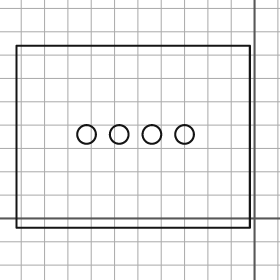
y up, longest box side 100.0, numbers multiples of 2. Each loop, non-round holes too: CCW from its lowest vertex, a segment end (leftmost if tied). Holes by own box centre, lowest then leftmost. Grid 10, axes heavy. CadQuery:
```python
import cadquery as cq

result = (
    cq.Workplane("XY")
    .moveTo(-102.0, -4.0)
    .lineTo(-2.0, -4.0)
    .lineTo(-2.0, 74.0)
    .lineTo(-102.0, 74.0)
    .close()
    .moveTo(-72.0, 36.0)
    .circle(4.0)
    .moveTo(-58.0, 36.0)
    .circle(4.0)
    .moveTo(-44.0, 36.0)
    .circle(4.0)
    .moveTo(-30.0, 36.0)
    .circle(4.0)
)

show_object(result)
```